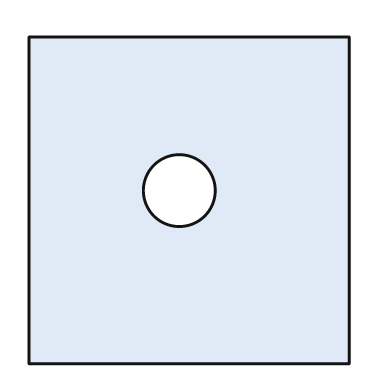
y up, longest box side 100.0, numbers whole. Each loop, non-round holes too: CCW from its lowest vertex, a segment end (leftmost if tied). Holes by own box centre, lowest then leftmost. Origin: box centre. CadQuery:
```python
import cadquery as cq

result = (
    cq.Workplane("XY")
    .moveTo(-49.0, -50.0)
    .lineTo(49.0, -50.0)
    .lineTo(49.0, 50.0)
    .lineTo(-49.0, 50.0)
    .close()
    .moveTo(-3.0, 3.0)
    .circle(11.0)
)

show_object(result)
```